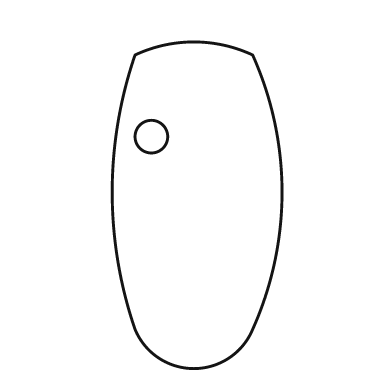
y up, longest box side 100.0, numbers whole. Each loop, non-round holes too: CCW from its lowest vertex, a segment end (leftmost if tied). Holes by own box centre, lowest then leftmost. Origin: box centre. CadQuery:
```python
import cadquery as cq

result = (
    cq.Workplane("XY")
    .moveTo(-19.0, -38.0)
    .threePointArc((-1.0, -50.0), (17.0, -38.0))
    .threePointArc((26.0, 4.0), (17.0, 46.0))
    .threePointArc((-1.0, 50.0), (-19.0, 46.0))
    .threePointArc((-26.0, 4.0), (-19.0, -38.0))
    .close()
    .moveTo(-14.0, 21.0)
    .circle(5.0)
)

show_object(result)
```